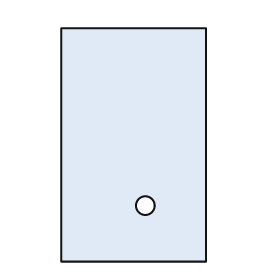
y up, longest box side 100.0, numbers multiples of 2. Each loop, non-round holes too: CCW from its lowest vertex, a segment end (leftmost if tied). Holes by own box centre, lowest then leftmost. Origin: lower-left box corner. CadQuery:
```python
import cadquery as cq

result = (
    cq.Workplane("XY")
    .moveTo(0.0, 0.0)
    .lineTo(62.0, 0.0)
    .lineTo(62.0, 100.0)
    .lineTo(0.0, 100.0)
    .close()
    .moveTo(36.0, 24.0)
    .circle(4.0)
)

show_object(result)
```